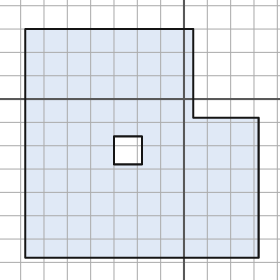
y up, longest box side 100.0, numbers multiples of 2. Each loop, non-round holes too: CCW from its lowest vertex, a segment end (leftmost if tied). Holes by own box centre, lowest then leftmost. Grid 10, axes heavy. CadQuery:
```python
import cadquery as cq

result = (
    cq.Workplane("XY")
    .moveTo(-68.0, -68.0)
    .lineTo(32.0, -68.0)
    .lineTo(32.0, -8.0)
    .lineTo(4.0, -8.0)
    .lineTo(4.0, 30.0)
    .lineTo(-68.0, 30.0)
    .close()
    .moveTo(-30.0, -28.0)
    .lineTo(-18.0, -28.0)
    .lineTo(-18.0, -16.0)
    .lineTo(-30.0, -16.0)
    .close()
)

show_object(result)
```